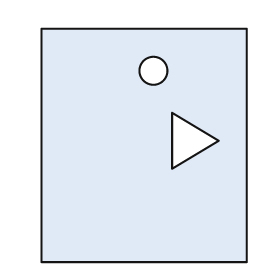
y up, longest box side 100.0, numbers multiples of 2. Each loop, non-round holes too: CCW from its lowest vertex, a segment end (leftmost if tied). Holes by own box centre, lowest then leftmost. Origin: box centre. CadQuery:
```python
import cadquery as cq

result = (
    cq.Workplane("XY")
    .moveTo(-44.0, -50.0)
    .lineTo(44.0, -50.0)
    .lineTo(44.0, 50.0)
    .lineTo(-44.0, 50.0)
    .close()
    .moveTo(12.0, -10.0)
    .lineTo(32.0, 2.0)
    .lineTo(12.0, 14.0)
    .close()
    .moveTo(4.0, 32.0)
    .circle(6.0)
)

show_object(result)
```